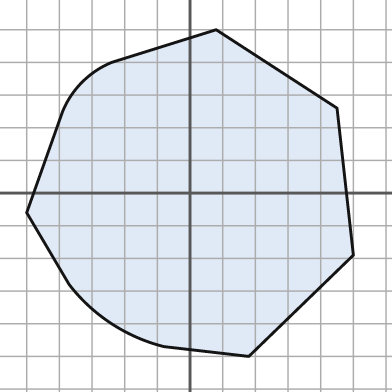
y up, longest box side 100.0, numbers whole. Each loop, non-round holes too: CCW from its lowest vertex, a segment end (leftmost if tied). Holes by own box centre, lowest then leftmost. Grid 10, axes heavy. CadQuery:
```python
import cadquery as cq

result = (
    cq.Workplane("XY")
    .moveTo(18.0, -50.0)
    .lineTo(50.0, -19.0)
    .lineTo(45.0, 26.0)
    .lineTo(8.0, 50.0)
    .lineTo(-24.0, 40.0)
    .threePointArc((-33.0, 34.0), (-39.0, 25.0))
    .lineTo(-50.0, -6.0)
    .lineTo(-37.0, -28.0)
    .threePointArc((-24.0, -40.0), (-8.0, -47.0))
    .close()
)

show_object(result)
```